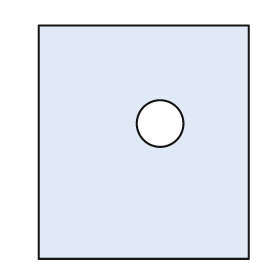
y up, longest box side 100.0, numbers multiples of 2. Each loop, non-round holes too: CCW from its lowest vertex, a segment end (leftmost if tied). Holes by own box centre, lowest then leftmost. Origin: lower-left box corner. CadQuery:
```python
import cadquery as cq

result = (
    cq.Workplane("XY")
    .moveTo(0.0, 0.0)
    .lineTo(90.0, 0.0)
    .lineTo(90.0, 100.0)
    .lineTo(0.0, 100.0)
    .close()
    .moveTo(52.0, 58.0)
    .circle(10.0)
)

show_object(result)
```